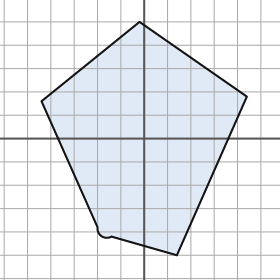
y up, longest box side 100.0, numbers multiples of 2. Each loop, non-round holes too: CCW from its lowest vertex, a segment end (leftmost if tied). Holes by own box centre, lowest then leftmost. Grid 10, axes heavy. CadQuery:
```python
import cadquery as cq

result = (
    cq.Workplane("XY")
    .moveTo(14.0, -50.0)
    .lineTo(44.0, 18.0)
    .lineTo(-2.0, 50.0)
    .lineTo(-44.0, 16.0)
    .lineTo(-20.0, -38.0)
    .threePointArc((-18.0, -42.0), (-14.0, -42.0))
    .close()
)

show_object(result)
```